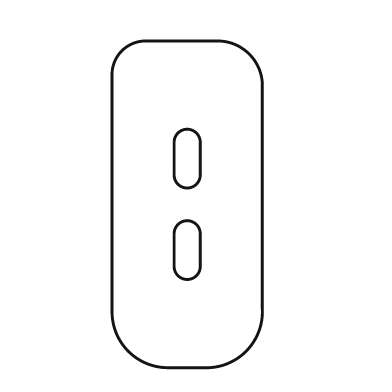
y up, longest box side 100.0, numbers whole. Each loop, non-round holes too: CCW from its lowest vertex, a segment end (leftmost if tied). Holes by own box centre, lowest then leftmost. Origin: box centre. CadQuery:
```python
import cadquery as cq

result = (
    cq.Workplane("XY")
    .moveTo(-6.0, -50.0)
    .lineTo(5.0, -50.0)
    .threePointArc((18.0, -45.0), (23.0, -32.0))
    .lineTo(23.0, 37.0)
    .threePointArc((19.0, 46.0), (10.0, 50.0))
    .lineTo(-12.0, 50.0)
    .threePointArc((-20.0, 47.0), (-23.0, 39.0))
    .lineTo(-23.0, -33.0)
    .threePointArc((-18.0, -45.0), (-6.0, -50.0))
    .close()
    .moveTo(-4.0, -19.0)
    .threePointArc((0.0, -23.0), (4.0, -19.0))
    .lineTo(4.0, -9.0)
    .threePointArc((0.0, -5.0), (-4.0, -9.0))
    .close()
    .moveTo(-4.0, 9.0)
    .threePointArc((0.0, 5.0), (4.0, 9.0))
    .lineTo(4.0, 19.0)
    .threePointArc((0.0, 23.0), (-4.0, 19.0))
    .close()
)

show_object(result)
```